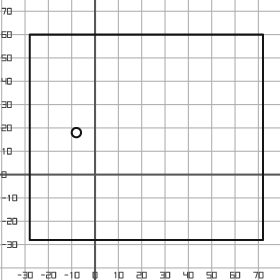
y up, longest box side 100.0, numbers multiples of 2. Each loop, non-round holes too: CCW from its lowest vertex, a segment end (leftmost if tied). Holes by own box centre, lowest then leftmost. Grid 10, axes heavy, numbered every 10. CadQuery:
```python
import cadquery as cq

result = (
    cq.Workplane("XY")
    .moveTo(-28.0, -28.0)
    .lineTo(72.0, -28.0)
    .lineTo(72.0, 60.0)
    .lineTo(-28.0, 60.0)
    .close()
    .moveTo(-8.0, 18.0)
    .circle(2.0)
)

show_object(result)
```